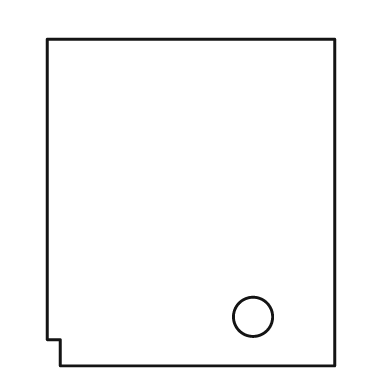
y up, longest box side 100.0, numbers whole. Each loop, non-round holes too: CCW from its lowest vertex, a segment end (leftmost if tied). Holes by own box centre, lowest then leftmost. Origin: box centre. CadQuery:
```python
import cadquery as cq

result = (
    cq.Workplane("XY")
    .moveTo(-40.0, -50.0)
    .lineTo(44.0, -50.0)
    .lineTo(44.0, 50.0)
    .lineTo(-44.0, 50.0)
    .lineTo(-44.0, -42.0)
    .lineTo(-40.0, -42.0)
    .close()
    .moveTo(19.0, -35.0)
    .circle(6.0)
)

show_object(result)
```